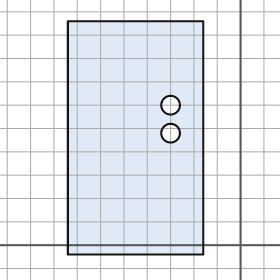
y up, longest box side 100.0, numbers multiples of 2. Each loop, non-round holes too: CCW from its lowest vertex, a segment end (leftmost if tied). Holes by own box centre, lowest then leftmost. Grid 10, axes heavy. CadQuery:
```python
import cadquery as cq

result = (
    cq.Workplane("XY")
    .moveTo(-74.0, -4.0)
    .lineTo(-16.0, -4.0)
    .lineTo(-16.0, 96.0)
    .lineTo(-74.0, 96.0)
    .close()
    .moveTo(-30.0, 48.0)
    .circle(4.0)
    .moveTo(-30.0, 60.0)
    .circle(4.0)
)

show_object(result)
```